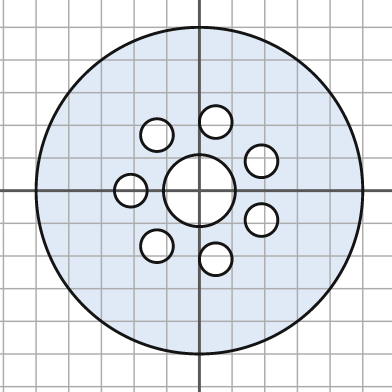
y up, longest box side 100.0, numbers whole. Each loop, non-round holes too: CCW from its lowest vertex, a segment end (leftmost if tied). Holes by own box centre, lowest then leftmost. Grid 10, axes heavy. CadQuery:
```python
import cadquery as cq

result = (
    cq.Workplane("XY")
    .moveTo(0.0, 0.0)
    .circle(50.0)
    .moveTo(5.0, -21.0)
    .circle(5.0)
    .moveTo(-13.0, -17.0)
    .circle(5.0)
    .moveTo(19.0, -9.0)
    .circle(5.0)
    .moveTo(-21.0, 0.0)
    .circle(5.0)
    .moveTo(0.0, 0.0)
    .circle(11.0)
    .moveTo(19.0, 9.0)
    .circle(5.0)
    .moveTo(-13.0, 17.0)
    .circle(5.0)
    .moveTo(5.0, 21.0)
    .circle(5.0)
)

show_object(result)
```